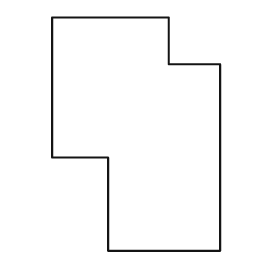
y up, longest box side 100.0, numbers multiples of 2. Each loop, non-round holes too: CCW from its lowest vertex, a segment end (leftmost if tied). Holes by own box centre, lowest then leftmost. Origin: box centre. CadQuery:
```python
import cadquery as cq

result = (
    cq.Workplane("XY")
    .moveTo(-12.0, -50.0)
    .lineTo(36.0, -50.0)
    .lineTo(36.0, 30.0)
    .lineTo(14.0, 30.0)
    .lineTo(14.0, 50.0)
    .lineTo(-36.0, 50.0)
    .lineTo(-36.0, -10.0)
    .lineTo(-12.0, -10.0)
    .close()
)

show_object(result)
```